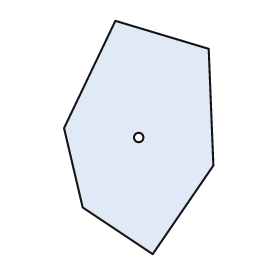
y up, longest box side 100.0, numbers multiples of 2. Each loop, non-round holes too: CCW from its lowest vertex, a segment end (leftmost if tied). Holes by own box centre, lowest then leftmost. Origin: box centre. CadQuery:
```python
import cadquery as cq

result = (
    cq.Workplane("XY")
    .moveTo(6.0, -50.0)
    .lineTo(32.0, -12.0)
    .lineTo(30.0, 38.0)
    .lineTo(-10.0, 50.0)
    .lineTo(-32.0, 4.0)
    .lineTo(-24.0, -30.0)
    .close()
    .moveTo(0.0, 0.0)
    .circle(2.0)
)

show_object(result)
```